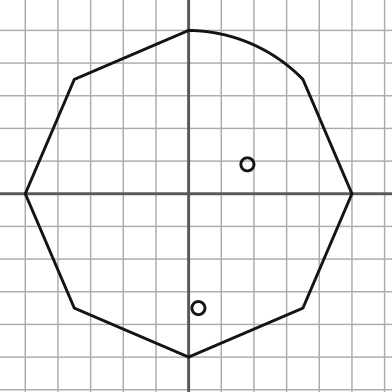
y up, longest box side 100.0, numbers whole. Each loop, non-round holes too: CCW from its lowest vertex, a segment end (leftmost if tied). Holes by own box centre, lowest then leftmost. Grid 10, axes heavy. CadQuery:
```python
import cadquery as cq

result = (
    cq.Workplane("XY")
    .moveTo(0.0, -50.0)
    .lineTo(35.0, -35.0)
    .lineTo(50.0, 0.0)
    .lineTo(35.0, 35.0)
    .threePointArc((19.0, 46.0), (0.0, 50.0))
    .lineTo(-35.0, 35.0)
    .lineTo(-50.0, 0.0)
    .lineTo(-35.0, -35.0)
    .close()
    .moveTo(3.0, -35.0)
    .circle(2.0)
    .moveTo(18.0, 9.0)
    .circle(2.0)
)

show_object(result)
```